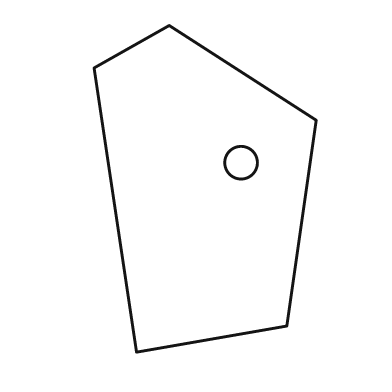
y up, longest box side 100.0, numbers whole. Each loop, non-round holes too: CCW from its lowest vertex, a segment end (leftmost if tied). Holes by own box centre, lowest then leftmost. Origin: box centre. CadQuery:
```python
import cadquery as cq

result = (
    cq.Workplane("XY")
    .moveTo(-21.0, -50.0)
    .lineTo(25.0, -42.0)
    .lineTo(34.0, 21.0)
    .lineTo(-11.0, 50.0)
    .lineTo(-34.0, 37.0)
    .close()
    .moveTo(11.0, 8.0)
    .circle(5.0)
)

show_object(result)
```